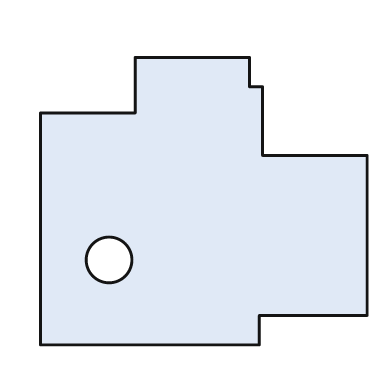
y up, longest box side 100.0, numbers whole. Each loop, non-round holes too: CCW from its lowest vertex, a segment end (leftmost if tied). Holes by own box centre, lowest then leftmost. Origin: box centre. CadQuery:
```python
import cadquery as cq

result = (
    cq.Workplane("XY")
    .moveTo(-50.0, -44.0)
    .lineTo(17.0, -44.0)
    .lineTo(17.0, -35.0)
    .lineTo(50.0, -35.0)
    .lineTo(50.0, 14.0)
    .lineTo(18.0, 14.0)
    .lineTo(18.0, 35.0)
    .lineTo(14.0, 35.0)
    .lineTo(14.0, 44.0)
    .lineTo(-21.0, 44.0)
    .lineTo(-21.0, 27.0)
    .lineTo(-50.0, 27.0)
    .close()
    .moveTo(-29.0, -18.0)
    .circle(7.0)
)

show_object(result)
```